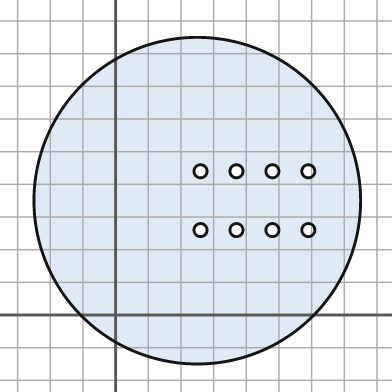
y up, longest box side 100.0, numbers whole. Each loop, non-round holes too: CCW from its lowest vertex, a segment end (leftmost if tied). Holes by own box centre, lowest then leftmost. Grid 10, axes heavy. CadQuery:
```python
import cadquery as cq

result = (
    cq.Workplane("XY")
    .moveTo(25.0, 35.0)
    .circle(50.0)
    .moveTo(26.0, 26.0)
    .circle(2.0)
    .moveTo(37.0, 26.0)
    .circle(2.0)
    .moveTo(48.0, 26.0)
    .circle(2.0)
    .moveTo(59.0, 26.0)
    .circle(2.0)
    .moveTo(26.0, 44.0)
    .circle(2.0)
    .moveTo(37.0, 44.0)
    .circle(2.0)
    .moveTo(48.0, 44.0)
    .circle(2.0)
    .moveTo(59.0, 44.0)
    .circle(2.0)
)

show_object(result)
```